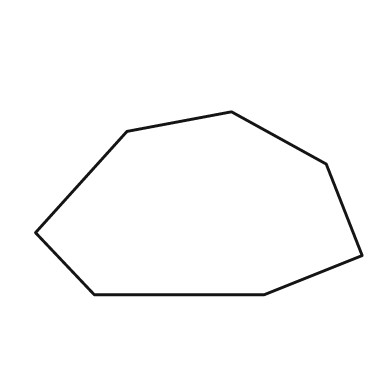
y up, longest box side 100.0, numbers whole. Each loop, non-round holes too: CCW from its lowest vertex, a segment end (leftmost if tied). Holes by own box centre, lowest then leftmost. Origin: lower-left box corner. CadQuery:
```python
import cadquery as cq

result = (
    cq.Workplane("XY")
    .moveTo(18.0, 0.0)
    .lineTo(70.0, 0.0)
    .lineTo(100.0, 12.0)
    .lineTo(89.0, 40.0)
    .lineTo(60.0, 56.0)
    .lineTo(28.0, 50.0)
    .lineTo(0.0, 19.0)
    .close()
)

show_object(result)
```